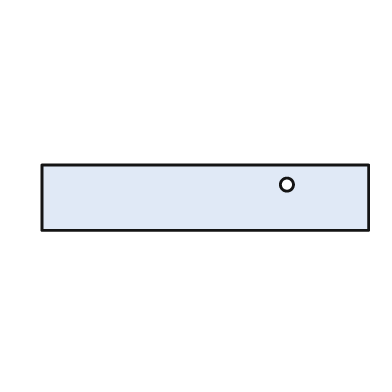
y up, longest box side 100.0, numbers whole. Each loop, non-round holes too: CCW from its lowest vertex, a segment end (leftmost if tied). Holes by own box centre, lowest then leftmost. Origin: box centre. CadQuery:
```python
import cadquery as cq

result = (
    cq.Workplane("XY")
    .moveTo(-50.0, -10.0)
    .lineTo(50.0, -10.0)
    .lineTo(50.0, 10.0)
    .lineTo(-50.0, 10.0)
    .close()
    .moveTo(25.0, 4.0)
    .circle(2.0)
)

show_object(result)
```